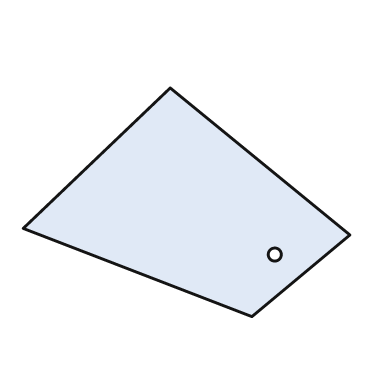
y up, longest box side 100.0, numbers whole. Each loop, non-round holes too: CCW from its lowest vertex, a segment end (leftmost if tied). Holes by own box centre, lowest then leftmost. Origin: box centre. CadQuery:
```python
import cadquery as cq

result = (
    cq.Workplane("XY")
    .moveTo(20.0, -35.0)
    .lineTo(50.0, -10.0)
    .lineTo(-5.0, 35.0)
    .lineTo(-50.0, -8.0)
    .close()
    .moveTo(27.0, -16.0)
    .circle(2.0)
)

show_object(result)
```